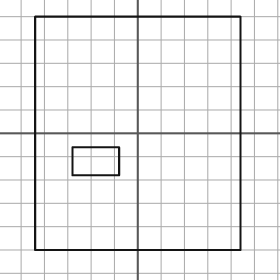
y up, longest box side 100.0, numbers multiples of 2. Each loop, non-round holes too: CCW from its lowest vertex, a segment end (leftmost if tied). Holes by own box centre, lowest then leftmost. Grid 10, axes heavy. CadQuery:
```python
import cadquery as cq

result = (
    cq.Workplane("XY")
    .moveTo(-44.0, -50.0)
    .lineTo(44.0, -50.0)
    .lineTo(44.0, 50.0)
    .lineTo(-44.0, 50.0)
    .close()
    .moveTo(-28.0, -18.0)
    .lineTo(-8.0, -18.0)
    .lineTo(-8.0, -6.0)
    .lineTo(-28.0, -6.0)
    .close()
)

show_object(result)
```